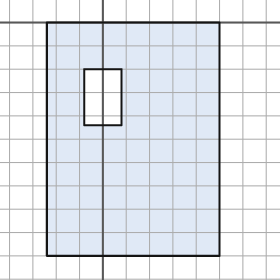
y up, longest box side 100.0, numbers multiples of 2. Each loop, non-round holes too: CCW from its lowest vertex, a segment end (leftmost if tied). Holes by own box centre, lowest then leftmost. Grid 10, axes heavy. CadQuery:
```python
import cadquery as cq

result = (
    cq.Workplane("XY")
    .moveTo(-24.0, -100.0)
    .lineTo(50.0, -100.0)
    .lineTo(50.0, 0.0)
    .lineTo(-24.0, 0.0)
    .close()
    .moveTo(-8.0, -44.0)
    .lineTo(8.0, -44.0)
    .lineTo(8.0, -20.0)
    .lineTo(-8.0, -20.0)
    .close()
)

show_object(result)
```